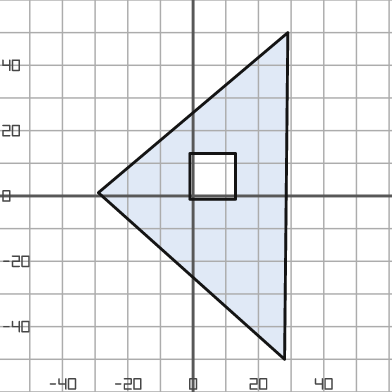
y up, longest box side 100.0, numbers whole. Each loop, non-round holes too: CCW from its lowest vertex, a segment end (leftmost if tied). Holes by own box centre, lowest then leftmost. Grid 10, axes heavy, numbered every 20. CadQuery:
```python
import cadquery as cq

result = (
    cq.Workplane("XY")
    .moveTo(28.0, -50.0)
    .lineTo(29.0, 50.0)
    .lineTo(-29.0, 1.0)
    .close()
    .moveTo(-1.0, -1.0)
    .lineTo(13.0, -1.0)
    .lineTo(13.0, 13.0)
    .lineTo(-1.0, 13.0)
    .close()
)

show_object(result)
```